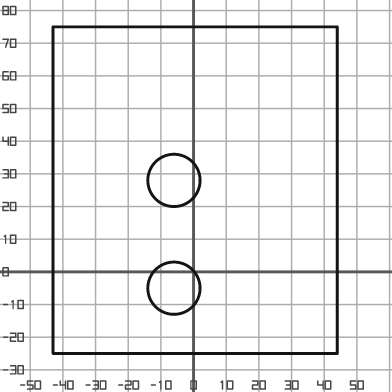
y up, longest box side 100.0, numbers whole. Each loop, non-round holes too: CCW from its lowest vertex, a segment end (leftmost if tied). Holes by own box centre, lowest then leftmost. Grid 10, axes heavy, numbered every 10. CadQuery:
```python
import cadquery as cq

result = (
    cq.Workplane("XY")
    .moveTo(-43.0, -25.0)
    .lineTo(44.0, -25.0)
    .lineTo(44.0, 75.0)
    .lineTo(-43.0, 75.0)
    .close()
    .moveTo(-6.0, -5.0)
    .circle(8.0)
    .moveTo(-6.0, 28.0)
    .circle(8.0)
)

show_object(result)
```